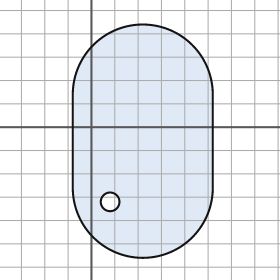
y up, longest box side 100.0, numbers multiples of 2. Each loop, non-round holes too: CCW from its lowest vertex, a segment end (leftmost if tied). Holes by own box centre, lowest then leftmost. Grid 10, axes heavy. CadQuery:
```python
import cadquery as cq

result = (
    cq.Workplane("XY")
    .moveTo(-8.0, -26.0)
    .threePointArc((22.0, -56.0), (52.0, -26.0))
    .lineTo(52.0, 14.0)
    .threePointArc((22.0, 44.0), (-8.0, 14.0))
    .close()
    .moveTo(8.0, -32.0)
    .circle(4.0)
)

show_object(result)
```